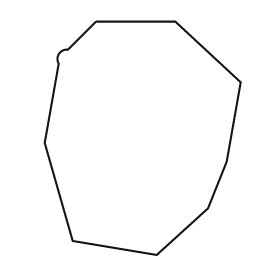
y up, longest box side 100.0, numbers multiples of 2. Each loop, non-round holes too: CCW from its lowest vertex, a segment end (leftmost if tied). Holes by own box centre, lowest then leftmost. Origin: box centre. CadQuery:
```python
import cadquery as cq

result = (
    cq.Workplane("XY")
    .moveTo(6.0, -50.0)
    .lineTo(28.0, -30.0)
    .lineTo(36.0, -10.0)
    .lineTo(42.0, 24.0)
    .lineTo(14.0, 50.0)
    .lineTo(-20.0, 50.0)
    .lineTo(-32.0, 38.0)
    .threePointArc((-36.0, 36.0), (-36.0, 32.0))
    .lineTo(-42.0, -2.0)
    .lineTo(-30.0, -44.0)
    .close()
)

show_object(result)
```